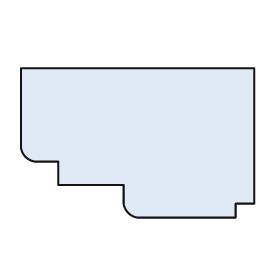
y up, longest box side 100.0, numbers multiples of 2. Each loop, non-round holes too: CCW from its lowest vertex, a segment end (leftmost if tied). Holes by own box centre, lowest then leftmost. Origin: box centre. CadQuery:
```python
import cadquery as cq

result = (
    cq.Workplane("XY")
    .moveTo(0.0, -32.0)
    .lineTo(42.0, -32.0)
    .lineTo(42.0, -26.0)
    .lineTo(50.0, -26.0)
    .lineTo(50.0, 32.0)
    .lineTo(-50.0, 32.0)
    .lineTo(-50.0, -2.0)
    .threePointArc((-48.0, -6.0), (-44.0, -8.0))
    .lineTo(-34.0, -8.0)
    .lineTo(-34.0, -18.0)
    .lineTo(-6.0, -18.0)
    .lineTo(-6.0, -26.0)
    .threePointArc((-4.0, -30.0), (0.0, -32.0))
    .close()
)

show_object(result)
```